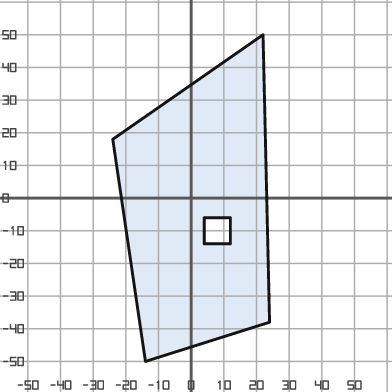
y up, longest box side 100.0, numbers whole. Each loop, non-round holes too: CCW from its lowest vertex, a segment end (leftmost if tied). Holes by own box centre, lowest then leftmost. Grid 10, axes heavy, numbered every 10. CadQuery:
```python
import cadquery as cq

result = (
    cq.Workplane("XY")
    .moveTo(-14.0, -50.0)
    .lineTo(24.0, -38.0)
    .lineTo(22.0, 50.0)
    .lineTo(-24.0, 18.0)
    .close()
    .moveTo(4.0, -14.0)
    .lineTo(12.0, -14.0)
    .lineTo(12.0, -6.0)
    .lineTo(4.0, -6.0)
    .close()
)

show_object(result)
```